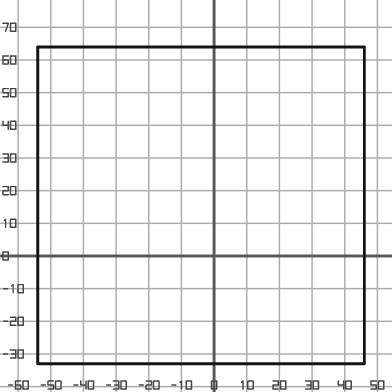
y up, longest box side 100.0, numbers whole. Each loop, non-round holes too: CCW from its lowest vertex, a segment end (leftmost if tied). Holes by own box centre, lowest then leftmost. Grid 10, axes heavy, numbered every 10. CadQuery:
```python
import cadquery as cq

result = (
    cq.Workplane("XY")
    .moveTo(-54.0, -33.0)
    .lineTo(46.0, -33.0)
    .lineTo(46.0, 64.0)
    .lineTo(-54.0, 64.0)
    .close()
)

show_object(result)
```